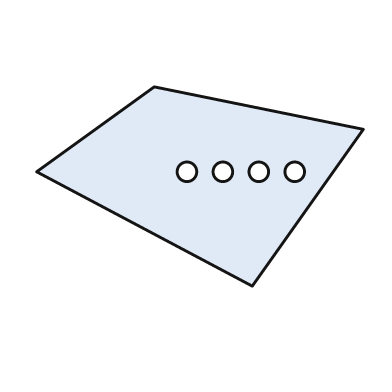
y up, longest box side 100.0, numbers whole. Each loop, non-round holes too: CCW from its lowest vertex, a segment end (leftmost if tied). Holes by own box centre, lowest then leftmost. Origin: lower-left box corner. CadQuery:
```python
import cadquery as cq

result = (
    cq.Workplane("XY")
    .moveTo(66.0, 0.0)
    .lineTo(100.0, 48.0)
    .lineTo(36.0, 61.0)
    .lineTo(0.0, 35.0)
    .close()
    .moveTo(46.0, 35.0)
    .circle(3.0)
    .moveTo(57.0, 35.0)
    .circle(3.0)
    .moveTo(68.0, 35.0)
    .circle(3.0)
    .moveTo(79.0, 35.0)
    .circle(3.0)
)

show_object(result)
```